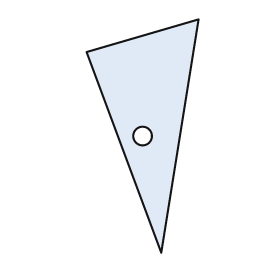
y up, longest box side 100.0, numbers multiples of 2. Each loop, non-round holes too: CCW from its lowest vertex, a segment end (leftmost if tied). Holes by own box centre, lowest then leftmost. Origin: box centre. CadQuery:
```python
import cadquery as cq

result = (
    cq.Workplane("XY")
    .moveTo(8.0, -50.0)
    .lineTo(24.0, 50.0)
    .lineTo(-24.0, 36.0)
    .close()
    .moveTo(0.0, 0.0)
    .circle(4.0)
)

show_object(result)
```